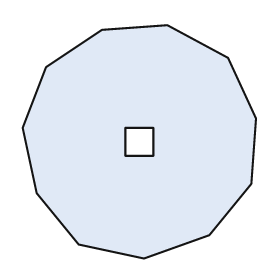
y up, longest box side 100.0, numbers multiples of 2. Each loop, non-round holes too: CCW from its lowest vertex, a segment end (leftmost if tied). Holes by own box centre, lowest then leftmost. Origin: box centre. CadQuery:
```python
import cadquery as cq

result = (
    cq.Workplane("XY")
    .moveTo(2.0, -50.0)
    .lineTo(30.0, -40.0)
    .lineTo(48.0, -18.0)
    .lineTo(50.0, 10.0)
    .lineTo(38.0, 36.0)
    .lineTo(12.0, 50.0)
    .lineTo(-16.0, 48.0)
    .lineTo(-40.0, 32.0)
    .lineTo(-50.0, 6.0)
    .lineTo(-44.0, -22.0)
    .lineTo(-26.0, -44.0)
    .close()
    .moveTo(-6.0, -6.0)
    .lineTo(6.0, -6.0)
    .lineTo(6.0, 6.0)
    .lineTo(-6.0, 6.0)
    .close()
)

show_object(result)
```